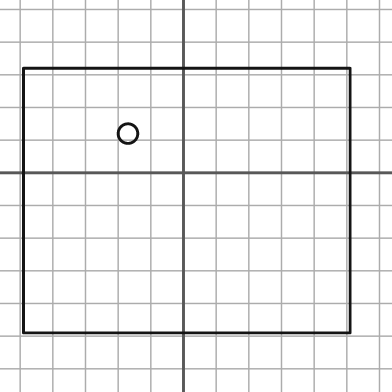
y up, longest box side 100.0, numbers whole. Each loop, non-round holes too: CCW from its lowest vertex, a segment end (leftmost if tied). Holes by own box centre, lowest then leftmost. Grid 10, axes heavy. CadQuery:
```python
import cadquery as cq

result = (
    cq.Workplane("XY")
    .moveTo(-49.0, -49.0)
    .lineTo(51.0, -49.0)
    .lineTo(51.0, 32.0)
    .lineTo(-49.0, 32.0)
    .close()
    .moveTo(-17.0, 12.0)
    .circle(3.0)
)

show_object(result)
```